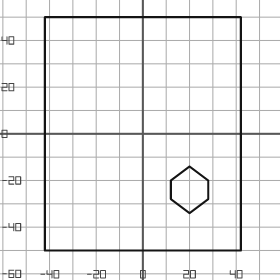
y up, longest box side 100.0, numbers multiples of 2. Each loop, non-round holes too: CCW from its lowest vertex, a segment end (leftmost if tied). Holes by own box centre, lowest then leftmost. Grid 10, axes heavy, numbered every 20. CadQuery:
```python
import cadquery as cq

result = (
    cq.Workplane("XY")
    .moveTo(-42.0, -50.0)
    .lineTo(42.0, -50.0)
    .lineTo(42.0, 50.0)
    .lineTo(-42.0, 50.0)
    .close()
    .moveTo(20.0, -34.0)
    .lineTo(28.0, -28.0)
    .lineTo(28.0, -20.0)
    .lineTo(20.0, -14.0)
    .lineTo(12.0, -20.0)
    .lineTo(12.0, -28.0)
    .close()
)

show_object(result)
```